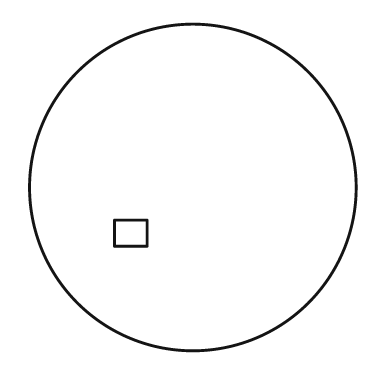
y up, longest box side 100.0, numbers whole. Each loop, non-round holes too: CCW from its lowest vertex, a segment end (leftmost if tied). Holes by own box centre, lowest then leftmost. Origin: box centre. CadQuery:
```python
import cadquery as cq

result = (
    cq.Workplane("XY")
    .moveTo(0.0, 0.0)
    .circle(50.0)
    .moveTo(-24.0, -18.0)
    .lineTo(-14.0, -18.0)
    .lineTo(-14.0, -10.0)
    .lineTo(-24.0, -10.0)
    .close()
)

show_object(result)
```